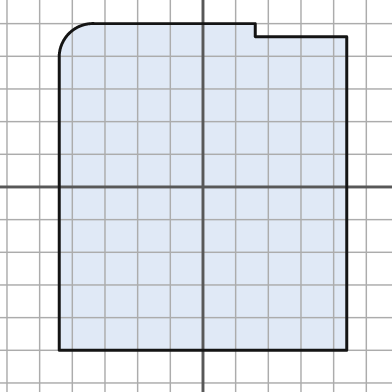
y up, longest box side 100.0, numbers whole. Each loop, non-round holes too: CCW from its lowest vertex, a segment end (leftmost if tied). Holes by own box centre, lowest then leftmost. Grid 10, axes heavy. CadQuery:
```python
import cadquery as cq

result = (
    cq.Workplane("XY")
    .moveTo(-44.0, -50.0)
    .lineTo(44.0, -50.0)
    .lineTo(44.0, 46.0)
    .lineTo(16.0, 46.0)
    .lineTo(16.0, 50.0)
    .lineTo(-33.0, 50.0)
    .threePointArc((-41.0, 47.0), (-44.0, 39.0))
    .close()
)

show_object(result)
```